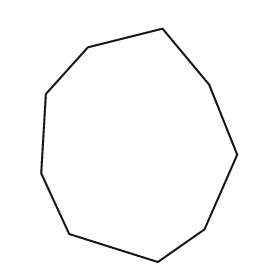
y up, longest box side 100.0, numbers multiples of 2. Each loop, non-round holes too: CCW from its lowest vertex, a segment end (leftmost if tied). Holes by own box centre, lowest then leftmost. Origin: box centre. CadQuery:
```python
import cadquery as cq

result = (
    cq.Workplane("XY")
    .moveTo(8.0, -50.0)
    .lineTo(28.0, -36.0)
    .lineTo(42.0, -4.0)
    .lineTo(30.0, 26.0)
    .lineTo(10.0, 50.0)
    .lineTo(-22.0, 42.0)
    .lineTo(-40.0, 22.0)
    .lineTo(-42.0, -12.0)
    .lineTo(-30.0, -38.0)
    .close()
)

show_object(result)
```